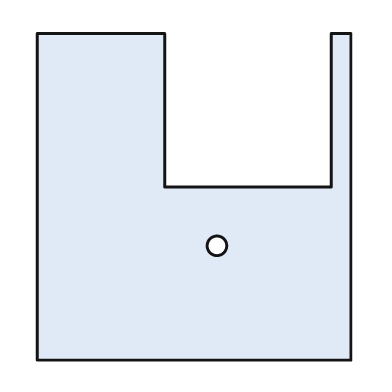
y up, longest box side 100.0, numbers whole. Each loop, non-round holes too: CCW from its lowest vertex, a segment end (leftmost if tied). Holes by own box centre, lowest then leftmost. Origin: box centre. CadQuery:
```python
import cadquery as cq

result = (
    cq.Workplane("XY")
    .moveTo(-48.0, -50.0)
    .lineTo(48.0, -50.0)
    .lineTo(48.0, 50.0)
    .lineTo(42.0, 50.0)
    .lineTo(42.0, 3.0)
    .lineTo(-9.0, 3.0)
    .lineTo(-9.0, 50.0)
    .lineTo(-48.0, 50.0)
    .close()
    .moveTo(7.0, -15.0)
    .circle(3.0)
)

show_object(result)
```